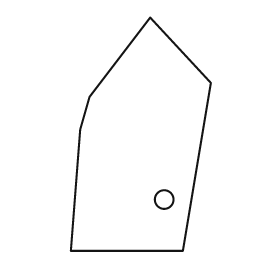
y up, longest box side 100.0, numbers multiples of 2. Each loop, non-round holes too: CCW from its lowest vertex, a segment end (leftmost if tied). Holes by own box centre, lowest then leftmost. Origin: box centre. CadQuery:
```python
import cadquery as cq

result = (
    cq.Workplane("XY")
    .moveTo(-30.0, -50.0)
    .lineTo(18.0, -50.0)
    .lineTo(30.0, 22.0)
    .lineTo(4.0, 50.0)
    .lineTo(-22.0, 16.0)
    .lineTo(-26.0, 2.0)
    .close()
    .moveTo(10.0, -28.0)
    .circle(4.0)
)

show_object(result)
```